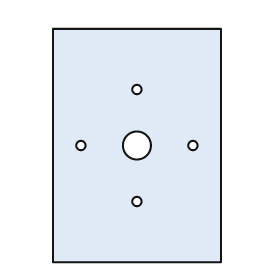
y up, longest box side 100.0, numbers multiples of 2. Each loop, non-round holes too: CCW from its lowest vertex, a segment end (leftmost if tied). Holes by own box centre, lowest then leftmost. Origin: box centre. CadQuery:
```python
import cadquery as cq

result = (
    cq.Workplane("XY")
    .moveTo(-36.0, -50.0)
    .lineTo(36.0, -50.0)
    .lineTo(36.0, 50.0)
    .lineTo(-36.0, 50.0)
    .close()
    .moveTo(0.0, -24.0)
    .circle(2.0)
    .moveTo(-24.0, 0.0)
    .circle(2.0)
    .moveTo(0.0, 0.0)
    .circle(6.0)
    .moveTo(24.0, 0.0)
    .circle(2.0)
    .moveTo(0.0, 24.0)
    .circle(2.0)
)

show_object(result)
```